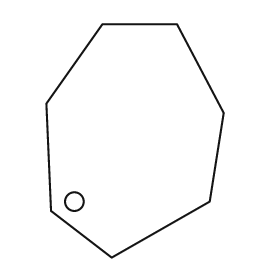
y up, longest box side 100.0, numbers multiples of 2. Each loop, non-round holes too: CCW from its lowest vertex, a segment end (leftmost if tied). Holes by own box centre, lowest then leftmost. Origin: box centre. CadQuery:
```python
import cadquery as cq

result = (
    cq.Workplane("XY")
    .moveTo(-10.0, -50.0)
    .lineTo(32.0, -26.0)
    .lineTo(38.0, 12.0)
    .lineTo(18.0, 50.0)
    .lineTo(-14.0, 50.0)
    .lineTo(-38.0, 16.0)
    .lineTo(-36.0, -30.0)
    .close()
    .moveTo(-26.0, -26.0)
    .circle(4.0)
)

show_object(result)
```